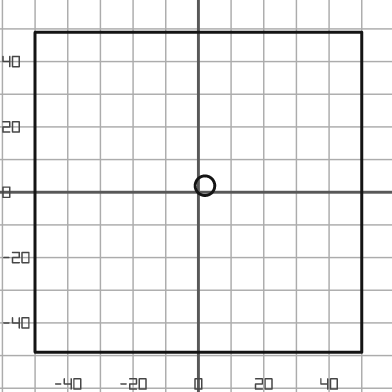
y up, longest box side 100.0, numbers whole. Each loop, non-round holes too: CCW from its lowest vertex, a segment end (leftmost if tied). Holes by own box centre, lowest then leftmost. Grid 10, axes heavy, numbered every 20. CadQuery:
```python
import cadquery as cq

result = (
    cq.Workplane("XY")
    .moveTo(-50.0, -49.0)
    .lineTo(50.0, -49.0)
    .lineTo(50.0, 49.0)
    .lineTo(-50.0, 49.0)
    .close()
    .moveTo(2.0, 2.0)
    .circle(3.0)
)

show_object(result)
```